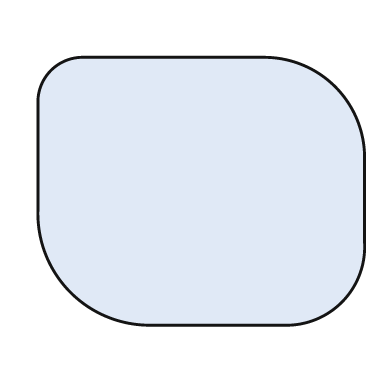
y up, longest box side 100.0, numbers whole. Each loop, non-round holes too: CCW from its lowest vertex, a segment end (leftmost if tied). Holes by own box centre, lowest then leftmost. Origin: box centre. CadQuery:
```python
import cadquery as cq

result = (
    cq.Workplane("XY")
    .moveTo(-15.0, -41.0)
    .lineTo(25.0, -41.0)
    .threePointArc((43.0, -34.0), (50.0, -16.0))
    .lineTo(50.0, 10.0)
    .threePointArc((41.0, 32.0), (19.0, 41.0))
    .lineTo(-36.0, 41.0)
    .threePointArc((-46.0, 37.0), (-50.0, 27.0))
    .lineTo(-50.0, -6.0)
    .threePointArc((-40.0, -31.0), (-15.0, -41.0))
    .close()
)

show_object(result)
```